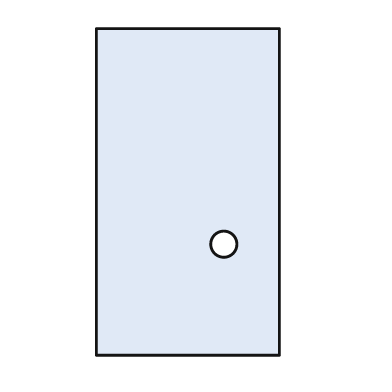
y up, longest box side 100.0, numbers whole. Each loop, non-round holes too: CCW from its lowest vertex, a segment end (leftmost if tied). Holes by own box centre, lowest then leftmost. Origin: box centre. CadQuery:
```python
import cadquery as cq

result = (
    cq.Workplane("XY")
    .moveTo(-28.0, -50.0)
    .lineTo(28.0, -50.0)
    .lineTo(28.0, 50.0)
    .lineTo(-28.0, 50.0)
    .close()
    .moveTo(11.0, -16.0)
    .circle(4.0)
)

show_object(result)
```